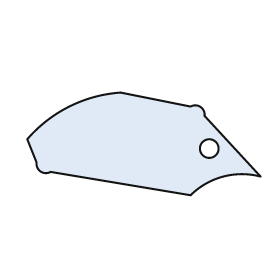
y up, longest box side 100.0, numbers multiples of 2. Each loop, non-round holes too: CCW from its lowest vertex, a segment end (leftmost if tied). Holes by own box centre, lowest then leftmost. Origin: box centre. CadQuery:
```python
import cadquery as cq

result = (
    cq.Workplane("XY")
    .moveTo(20.0, -22.0)
    .threePointArc((34.0, -14.0), (50.0, -14.0))
    .lineTo(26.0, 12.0)
    .threePointArc((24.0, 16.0), (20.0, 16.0))
    .lineTo(-10.0, 22.0)
    .threePointArc((-32.0, 16.0), (-50.0, 2.0))
    .lineTo(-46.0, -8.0)
    .threePointArc((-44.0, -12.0), (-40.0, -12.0))
    .close()
    .moveTo(28.0, -2.0)
    .circle(4.0)
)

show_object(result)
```